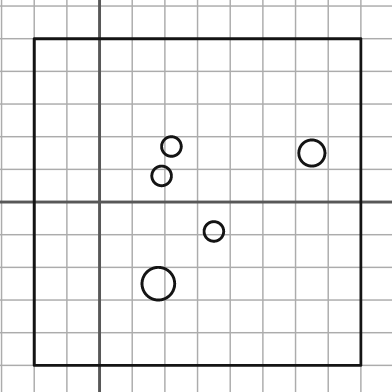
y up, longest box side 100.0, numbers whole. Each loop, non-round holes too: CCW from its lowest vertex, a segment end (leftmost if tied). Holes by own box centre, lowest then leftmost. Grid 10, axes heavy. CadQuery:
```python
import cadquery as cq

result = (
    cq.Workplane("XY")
    .moveTo(-20.0, -50.0)
    .lineTo(80.0, -50.0)
    .lineTo(80.0, 50.0)
    .lineTo(-20.0, 50.0)
    .close()
    .moveTo(18.0, -25.0)
    .circle(5.0)
    .moveTo(35.0, -9.0)
    .circle(3.0)
    .moveTo(19.0, 8.0)
    .circle(3.0)
    .moveTo(65.0, 15.0)
    .circle(4.0)
    .moveTo(22.0, 17.0)
    .circle(3.0)
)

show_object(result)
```